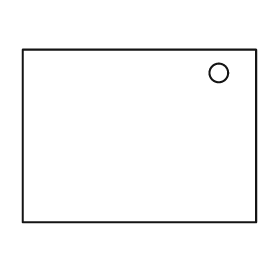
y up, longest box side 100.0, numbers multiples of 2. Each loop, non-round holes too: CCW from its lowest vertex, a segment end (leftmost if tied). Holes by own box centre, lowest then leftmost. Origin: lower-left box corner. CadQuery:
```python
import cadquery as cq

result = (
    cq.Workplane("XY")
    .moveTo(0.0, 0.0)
    .lineTo(100.0, 0.0)
    .lineTo(100.0, 74.0)
    .lineTo(0.0, 74.0)
    .close()
    .moveTo(84.0, 64.0)
    .circle(4.0)
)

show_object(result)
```